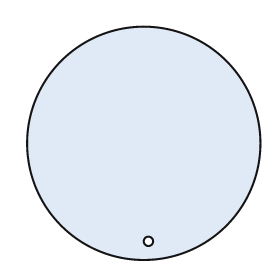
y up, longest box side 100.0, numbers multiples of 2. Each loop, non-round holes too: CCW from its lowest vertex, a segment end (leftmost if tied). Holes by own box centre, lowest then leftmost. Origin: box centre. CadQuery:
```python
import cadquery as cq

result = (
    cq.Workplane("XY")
    .moveTo(0.0, 0.0)
    .circle(50.0)
    .moveTo(2.0, -42.0)
    .circle(2.0)
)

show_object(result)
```